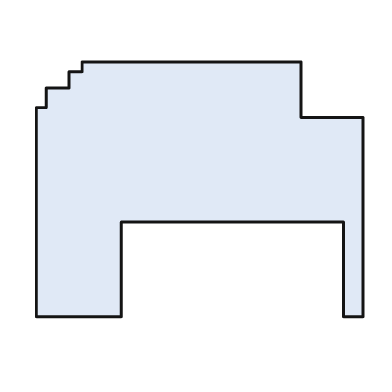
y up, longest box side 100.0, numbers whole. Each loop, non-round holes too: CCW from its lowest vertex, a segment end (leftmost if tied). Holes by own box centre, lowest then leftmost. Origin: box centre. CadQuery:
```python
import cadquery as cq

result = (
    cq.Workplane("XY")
    .moveTo(-50.0, -39.0)
    .lineTo(-24.0, -39.0)
    .lineTo(-24.0, -10.0)
    .lineTo(44.0, -10.0)
    .lineTo(44.0, -39.0)
    .lineTo(50.0, -39.0)
    .lineTo(50.0, 22.0)
    .lineTo(31.0, 22.0)
    .lineTo(31.0, 39.0)
    .lineTo(-36.0, 39.0)
    .lineTo(-36.0, 36.0)
    .lineTo(-40.0, 36.0)
    .lineTo(-40.0, 31.0)
    .lineTo(-47.0, 31.0)
    .lineTo(-47.0, 25.0)
    .lineTo(-50.0, 25.0)
    .close()
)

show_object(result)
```